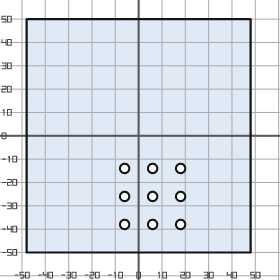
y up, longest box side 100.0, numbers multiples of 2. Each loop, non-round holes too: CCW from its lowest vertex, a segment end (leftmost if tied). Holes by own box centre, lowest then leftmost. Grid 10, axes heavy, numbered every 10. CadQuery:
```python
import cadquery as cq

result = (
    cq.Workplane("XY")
    .moveTo(-48.0, -50.0)
    .lineTo(48.0, -50.0)
    .lineTo(48.0, 50.0)
    .lineTo(-48.0, 50.0)
    .close()
    .moveTo(-6.0, -38.0)
    .circle(2.0)
    .moveTo(6.0, -38.0)
    .circle(2.0)
    .moveTo(18.0, -38.0)
    .circle(2.0)
    .moveTo(-6.0, -26.0)
    .circle(2.0)
    .moveTo(6.0, -26.0)
    .circle(2.0)
    .moveTo(18.0, -26.0)
    .circle(2.0)
    .moveTo(-6.0, -14.0)
    .circle(2.0)
    .moveTo(6.0, -14.0)
    .circle(2.0)
    .moveTo(18.0, -14.0)
    .circle(2.0)
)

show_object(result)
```